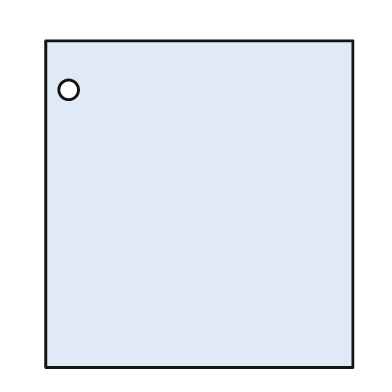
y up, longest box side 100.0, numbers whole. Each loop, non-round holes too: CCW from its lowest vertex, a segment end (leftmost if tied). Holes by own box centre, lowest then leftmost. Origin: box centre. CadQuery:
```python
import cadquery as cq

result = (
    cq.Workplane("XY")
    .moveTo(-47.0, -50.0)
    .lineTo(47.0, -50.0)
    .lineTo(47.0, 50.0)
    .lineTo(-47.0, 50.0)
    .close()
    .moveTo(-40.0, 35.0)
    .circle(3.0)
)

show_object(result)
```